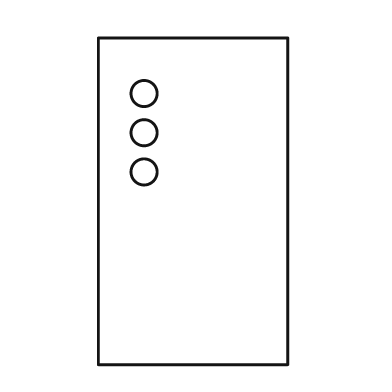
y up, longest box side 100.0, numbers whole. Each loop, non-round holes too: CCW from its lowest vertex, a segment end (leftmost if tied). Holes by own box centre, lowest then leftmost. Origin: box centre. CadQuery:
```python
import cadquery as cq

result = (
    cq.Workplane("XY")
    .moveTo(-29.0, -50.0)
    .lineTo(29.0, -50.0)
    .lineTo(29.0, 50.0)
    .lineTo(-29.0, 50.0)
    .close()
    .moveTo(-15.0, 9.0)
    .circle(4.0)
    .moveTo(-15.0, 21.0)
    .circle(4.0)
    .moveTo(-15.0, 33.0)
    .circle(4.0)
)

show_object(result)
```